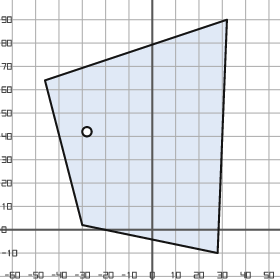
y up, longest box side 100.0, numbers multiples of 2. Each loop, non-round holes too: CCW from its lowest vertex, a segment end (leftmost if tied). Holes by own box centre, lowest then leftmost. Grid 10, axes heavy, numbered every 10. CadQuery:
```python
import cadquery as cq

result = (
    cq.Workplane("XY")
    .moveTo(28.0, -10.0)
    .lineTo(32.0, 90.0)
    .lineTo(-46.0, 64.0)
    .lineTo(-30.0, 2.0)
    .close()
    .moveTo(-28.0, 42.0)
    .circle(2.0)
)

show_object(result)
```